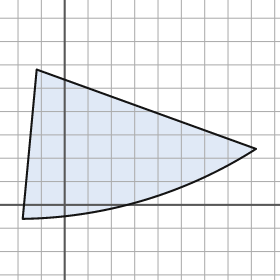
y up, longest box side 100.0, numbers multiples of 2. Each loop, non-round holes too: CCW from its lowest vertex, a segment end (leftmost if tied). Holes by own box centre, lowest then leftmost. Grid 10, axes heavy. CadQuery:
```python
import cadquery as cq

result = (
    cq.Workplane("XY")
    .moveTo(-18.0, -6.0)
    .threePointArc((34.0, 2.0), (82.0, 24.0))
    .lineTo(-12.0, 58.0)
    .close()
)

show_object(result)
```